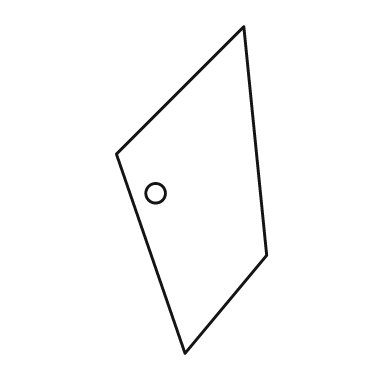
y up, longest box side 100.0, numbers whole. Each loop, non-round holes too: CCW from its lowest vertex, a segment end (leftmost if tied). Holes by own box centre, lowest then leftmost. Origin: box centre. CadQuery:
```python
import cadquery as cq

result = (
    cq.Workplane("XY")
    .moveTo(-2.0, -50.0)
    .lineTo(23.0, -20.0)
    .lineTo(16.0, 50.0)
    .lineTo(-23.0, 11.0)
    .close()
    .moveTo(-11.0, -1.0)
    .circle(3.0)
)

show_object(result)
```